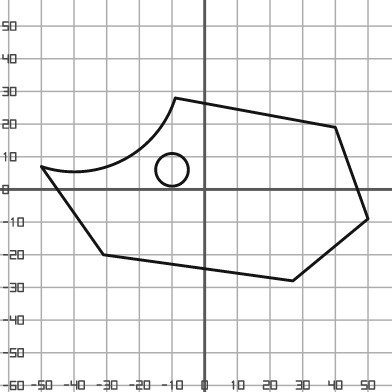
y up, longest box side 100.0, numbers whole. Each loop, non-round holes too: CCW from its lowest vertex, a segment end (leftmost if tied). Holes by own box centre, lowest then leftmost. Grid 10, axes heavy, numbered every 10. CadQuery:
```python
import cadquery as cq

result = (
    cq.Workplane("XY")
    .moveTo(27.0, -28.0)
    .lineTo(50.0, -9.0)
    .lineTo(40.0, 19.0)
    .lineTo(-9.0, 28.0)
    .threePointArc((-25.0, 9.0), (-50.0, 7.0))
    .lineTo(-31.0, -20.0)
    .close()
    .moveTo(-10.0, 6.0)
    .circle(5.0)
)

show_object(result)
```